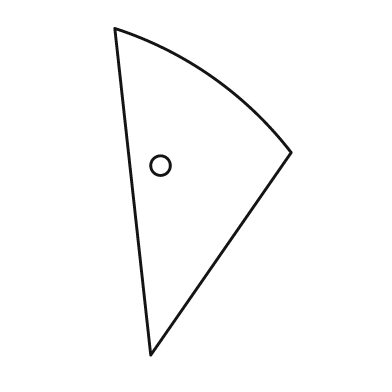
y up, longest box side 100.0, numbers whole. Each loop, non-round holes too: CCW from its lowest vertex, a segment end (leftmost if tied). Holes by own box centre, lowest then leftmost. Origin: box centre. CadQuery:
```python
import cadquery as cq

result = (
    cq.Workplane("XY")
    .moveTo(-16.0, -50.0)
    .lineTo(27.0, 12.0)
    .threePointArc((3.0, 35.0), (-27.0, 50.0))
    .close()
    .moveTo(-13.0, 8.0)
    .circle(3.0)
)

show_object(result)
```